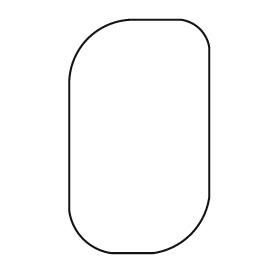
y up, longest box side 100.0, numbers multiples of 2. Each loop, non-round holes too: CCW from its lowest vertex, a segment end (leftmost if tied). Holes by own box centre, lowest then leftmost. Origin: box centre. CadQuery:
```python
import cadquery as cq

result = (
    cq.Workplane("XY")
    .moveTo(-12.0, -50.0)
    .lineTo(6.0, -50.0)
    .threePointArc((22.0, -42.0), (30.0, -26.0))
    .lineTo(30.0, 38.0)
    .threePointArc((26.0, 46.0), (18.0, 50.0))
    .lineTo(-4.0, 50.0)
    .threePointArc((-22.0, 42.0), (-30.0, 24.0))
    .lineTo(-30.0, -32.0)
    .threePointArc((-24.0, -44.0), (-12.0, -50.0))
    .close()
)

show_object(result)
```